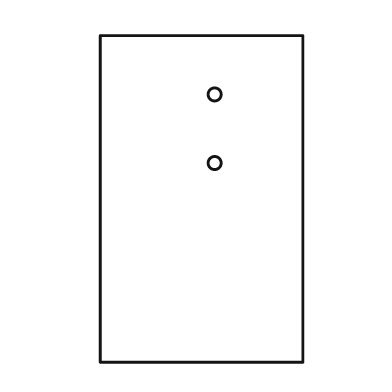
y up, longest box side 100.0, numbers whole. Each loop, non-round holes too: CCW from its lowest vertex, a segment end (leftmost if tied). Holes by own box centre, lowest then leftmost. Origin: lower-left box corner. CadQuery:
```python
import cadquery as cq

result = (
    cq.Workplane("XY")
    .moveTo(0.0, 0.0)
    .lineTo(62.0, 0.0)
    .lineTo(62.0, 100.0)
    .lineTo(0.0, 100.0)
    .close()
    .moveTo(35.0, 61.0)
    .circle(2.0)
    .moveTo(35.0, 82.0)
    .circle(2.0)
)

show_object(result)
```